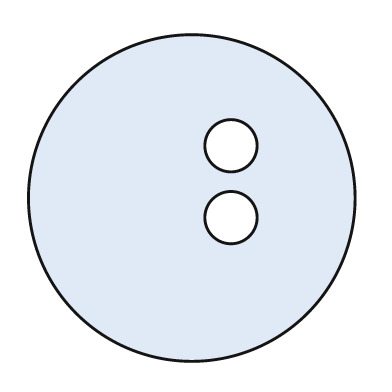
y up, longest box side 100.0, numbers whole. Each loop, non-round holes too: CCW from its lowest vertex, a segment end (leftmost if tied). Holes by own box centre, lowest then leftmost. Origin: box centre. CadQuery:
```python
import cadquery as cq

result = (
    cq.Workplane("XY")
    .moveTo(0.0, 0.0)
    .circle(50.0)
    .moveTo(12.0, -6.0)
    .circle(8.0)
    .moveTo(12.0, 16.0)
    .circle(8.0)
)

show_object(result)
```